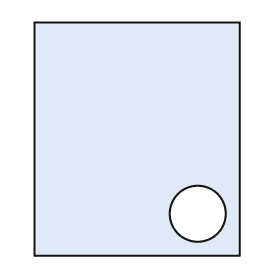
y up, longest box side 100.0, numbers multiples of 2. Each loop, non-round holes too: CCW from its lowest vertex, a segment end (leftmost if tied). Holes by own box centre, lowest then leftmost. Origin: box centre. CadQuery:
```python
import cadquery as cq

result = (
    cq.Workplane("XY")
    .moveTo(-44.0, -50.0)
    .lineTo(44.0, -50.0)
    .lineTo(44.0, 50.0)
    .lineTo(-44.0, 50.0)
    .close()
    .moveTo(26.0, -32.0)
    .circle(12.0)
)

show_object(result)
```